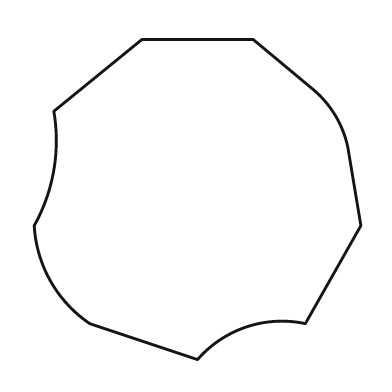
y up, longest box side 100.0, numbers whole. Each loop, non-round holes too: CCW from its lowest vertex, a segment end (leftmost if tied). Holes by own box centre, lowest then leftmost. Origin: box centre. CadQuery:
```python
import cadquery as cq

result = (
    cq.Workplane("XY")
    .moveTo(0.0, -49.0)
    .threePointArc((15.0, -39.0), (33.0, -38.0))
    .lineTo(50.0, -8.0)
    .lineTo(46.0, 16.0)
    .threePointArc((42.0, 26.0), (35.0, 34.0))
    .lineTo(17.0, 49.0)
    .lineTo(-17.0, 49.0)
    .lineTo(-44.0, 27.0)
    .threePointArc((-44.0, 9.0), (-50.0, -8.0))
    .threePointArc((-45.0, -25.0), (-33.0, -38.0))
    .close()
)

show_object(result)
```